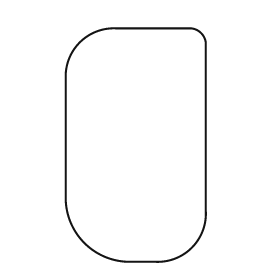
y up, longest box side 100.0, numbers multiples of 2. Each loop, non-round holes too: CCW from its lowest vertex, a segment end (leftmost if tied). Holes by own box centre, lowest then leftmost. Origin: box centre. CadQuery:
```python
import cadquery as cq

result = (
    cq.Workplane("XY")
    .moveTo(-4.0, -50.0)
    .lineTo(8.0, -50.0)
    .threePointArc((24.0, -44.0), (30.0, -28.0))
    .lineTo(30.0, 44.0)
    .threePointArc((28.0, 48.0), (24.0, 50.0))
    .lineTo(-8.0, 50.0)
    .threePointArc((-24.0, 44.0), (-30.0, 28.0))
    .lineTo(-30.0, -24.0)
    .threePointArc((-22.0, -42.0), (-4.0, -50.0))
    .close()
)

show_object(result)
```